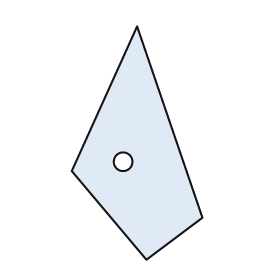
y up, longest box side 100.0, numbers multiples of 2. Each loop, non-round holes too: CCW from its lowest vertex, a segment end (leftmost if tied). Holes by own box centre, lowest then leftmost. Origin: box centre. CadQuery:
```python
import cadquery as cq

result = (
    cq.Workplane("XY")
    .moveTo(4.0, -50.0)
    .lineTo(28.0, -32.0)
    .lineTo(0.0, 50.0)
    .lineTo(-28.0, -12.0)
    .close()
    .moveTo(-6.0, -8.0)
    .circle(4.0)
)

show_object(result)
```